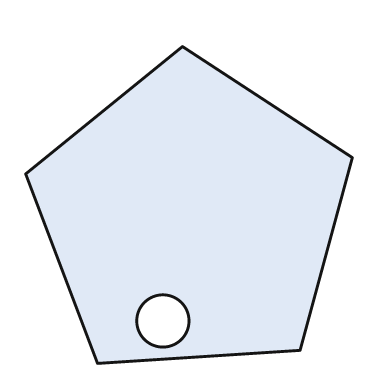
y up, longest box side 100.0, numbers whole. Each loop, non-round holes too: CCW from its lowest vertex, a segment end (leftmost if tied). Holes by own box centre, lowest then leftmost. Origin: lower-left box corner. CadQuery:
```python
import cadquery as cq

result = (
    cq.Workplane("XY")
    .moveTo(22.0, 0.0)
    .lineTo(84.0, 4.0)
    .lineTo(100.0, 63.0)
    .lineTo(48.0, 97.0)
    .lineTo(0.0, 58.0)
    .close()
    .moveTo(42.0, 13.0)
    .circle(8.0)
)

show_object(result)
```